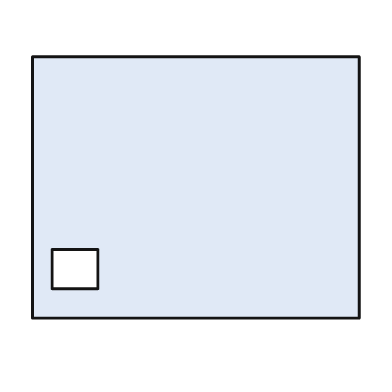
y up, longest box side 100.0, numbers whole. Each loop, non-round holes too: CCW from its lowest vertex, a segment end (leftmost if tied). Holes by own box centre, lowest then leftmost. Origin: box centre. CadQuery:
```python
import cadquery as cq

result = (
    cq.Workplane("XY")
    .moveTo(-50.0, -40.0)
    .lineTo(50.0, -40.0)
    .lineTo(50.0, 40.0)
    .lineTo(-50.0, 40.0)
    .close()
    .moveTo(-44.0, -31.0)
    .lineTo(-30.0, -31.0)
    .lineTo(-30.0, -19.0)
    .lineTo(-44.0, -19.0)
    .close()
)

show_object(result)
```